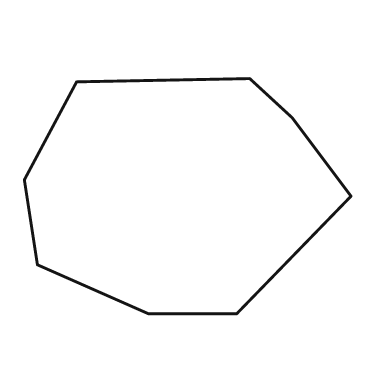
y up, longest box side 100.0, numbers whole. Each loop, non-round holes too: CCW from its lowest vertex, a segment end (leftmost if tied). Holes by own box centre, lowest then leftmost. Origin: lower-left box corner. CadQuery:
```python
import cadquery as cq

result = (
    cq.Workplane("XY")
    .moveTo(38.0, 0.0)
    .lineTo(65.0, 0.0)
    .lineTo(100.0, 36.0)
    .lineTo(82.0, 60.0)
    .lineTo(69.0, 72.0)
    .lineTo(16.0, 71.0)
    .lineTo(0.0, 41.0)
    .lineTo(4.0, 15.0)
    .close()
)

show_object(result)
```